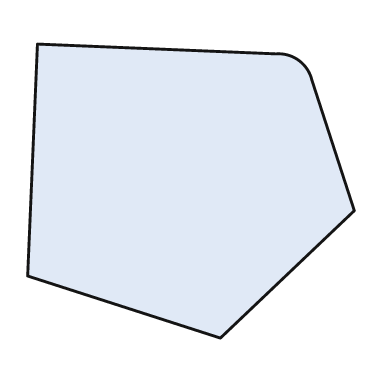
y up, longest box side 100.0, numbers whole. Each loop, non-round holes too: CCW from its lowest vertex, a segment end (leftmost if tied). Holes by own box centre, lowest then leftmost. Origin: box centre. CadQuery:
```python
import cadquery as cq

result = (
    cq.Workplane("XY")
    .moveTo(9.0, -45.0)
    .lineTo(50.0, -6.0)
    .lineTo(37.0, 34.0)
    .threePointArc((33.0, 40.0), (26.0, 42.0))
    .lineTo(-47.0, 45.0)
    .lineTo(-50.0, -26.0)
    .close()
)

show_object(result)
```